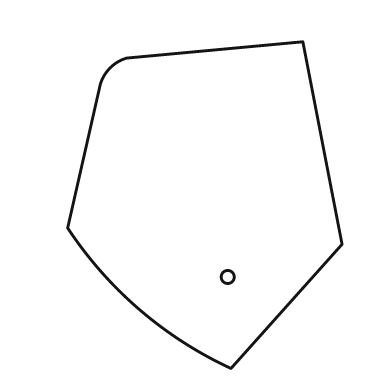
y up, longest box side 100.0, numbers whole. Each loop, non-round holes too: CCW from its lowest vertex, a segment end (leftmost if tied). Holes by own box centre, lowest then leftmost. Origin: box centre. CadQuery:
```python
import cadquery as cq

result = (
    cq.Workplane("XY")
    .moveTo(8.0, -50.0)
    .lineTo(42.0, -12.0)
    .lineTo(30.0, 50.0)
    .lineTo(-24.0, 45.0)
    .threePointArc((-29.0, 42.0), (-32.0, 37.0))
    .lineTo(-42.0, -7.0)
    .threePointArc((-20.0, -32.0), (8.0, -50.0))
    .close()
    .moveTo(7.0, -22.0)
    .circle(2.0)
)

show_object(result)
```